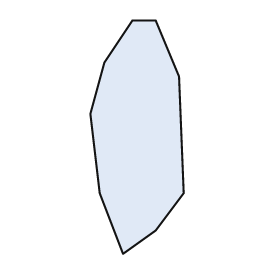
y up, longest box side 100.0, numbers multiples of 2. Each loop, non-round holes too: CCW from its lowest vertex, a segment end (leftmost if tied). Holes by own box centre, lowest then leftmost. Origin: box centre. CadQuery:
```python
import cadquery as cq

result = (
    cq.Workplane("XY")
    .moveTo(-6.0, -50.0)
    .lineTo(8.0, -40.0)
    .lineTo(20.0, -24.0)
    .lineTo(18.0, 26.0)
    .lineTo(8.0, 50.0)
    .lineTo(-2.0, 50.0)
    .lineTo(-14.0, 32.0)
    .lineTo(-20.0, 10.0)
    .lineTo(-16.0, -24.0)
    .close()
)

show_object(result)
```